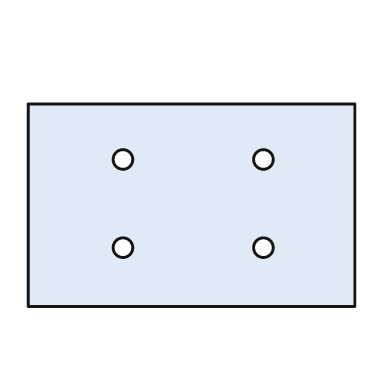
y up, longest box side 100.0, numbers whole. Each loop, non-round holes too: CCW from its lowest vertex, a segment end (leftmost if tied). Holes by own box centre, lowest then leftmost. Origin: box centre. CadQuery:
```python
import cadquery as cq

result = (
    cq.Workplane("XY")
    .moveTo(-50.0, -31.0)
    .lineTo(50.0, -31.0)
    .lineTo(50.0, 31.0)
    .lineTo(-50.0, 31.0)
    .close()
    .moveTo(-21.0, -13.0)
    .circle(3.0)
    .moveTo(22.0, -13.0)
    .circle(3.0)
    .moveTo(-21.0, 14.0)
    .circle(3.0)
    .moveTo(22.0, 14.0)
    .circle(3.0)
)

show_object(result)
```